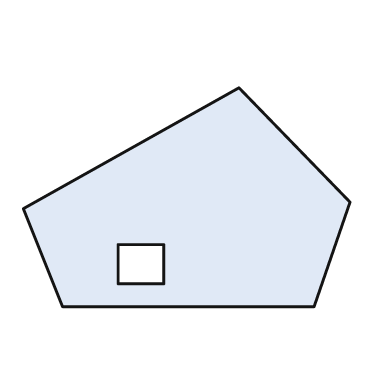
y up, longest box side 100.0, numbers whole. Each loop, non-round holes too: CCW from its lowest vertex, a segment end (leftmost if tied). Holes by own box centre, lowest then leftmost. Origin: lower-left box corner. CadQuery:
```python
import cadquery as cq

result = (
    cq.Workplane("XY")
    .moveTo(12.0, 0.0)
    .lineTo(89.0, 0.0)
    .lineTo(100.0, 32.0)
    .lineTo(66.0, 67.0)
    .lineTo(0.0, 30.0)
    .close()
    .moveTo(29.0, 7.0)
    .lineTo(43.0, 7.0)
    .lineTo(43.0, 19.0)
    .lineTo(29.0, 19.0)
    .close()
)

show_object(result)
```